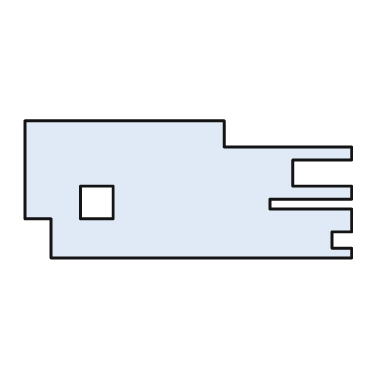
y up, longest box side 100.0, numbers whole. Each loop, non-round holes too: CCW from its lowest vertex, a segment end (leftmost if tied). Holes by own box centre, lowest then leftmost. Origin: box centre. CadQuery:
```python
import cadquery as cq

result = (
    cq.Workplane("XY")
    .moveTo(-42.0, -21.0)
    .lineTo(50.0, -21.0)
    .lineTo(50.0, -18.0)
    .lineTo(44.0, -18.0)
    .lineTo(44.0, -13.0)
    .lineTo(50.0, -13.0)
    .lineTo(50.0, -6.0)
    .lineTo(25.0, -6.0)
    .lineTo(25.0, -3.0)
    .lineTo(50.0, -3.0)
    .lineTo(50.0, 1.0)
    .lineTo(32.0, 1.0)
    .lineTo(32.0, 9.0)
    .lineTo(50.0, 9.0)
    .lineTo(50.0, 13.0)
    .lineTo(11.0, 13.0)
    .lineTo(11.0, 21.0)
    .lineTo(-50.0, 21.0)
    .lineTo(-50.0, -9.0)
    .lineTo(-42.0, -9.0)
    .close()
    .moveTo(-33.0, -9.0)
    .lineTo(-23.0, -9.0)
    .lineTo(-23.0, 1.0)
    .lineTo(-33.0, 1.0)
    .close()
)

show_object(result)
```